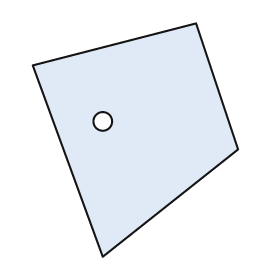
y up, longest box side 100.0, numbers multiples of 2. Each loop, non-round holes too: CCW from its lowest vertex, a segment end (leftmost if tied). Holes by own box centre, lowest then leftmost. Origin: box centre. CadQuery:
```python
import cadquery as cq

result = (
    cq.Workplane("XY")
    .moveTo(-14.0, -50.0)
    .lineTo(44.0, -4.0)
    .lineTo(26.0, 50.0)
    .lineTo(-44.0, 32.0)
    .close()
    .moveTo(-14.0, 8.0)
    .circle(4.0)
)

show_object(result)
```